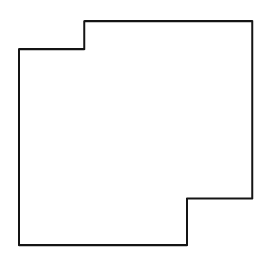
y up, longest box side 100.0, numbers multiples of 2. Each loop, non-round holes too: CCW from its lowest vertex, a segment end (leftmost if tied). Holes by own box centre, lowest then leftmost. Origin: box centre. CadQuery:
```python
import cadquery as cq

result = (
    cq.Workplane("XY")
    .moveTo(-50.0, -48.0)
    .lineTo(22.0, -48.0)
    .lineTo(22.0, -28.0)
    .lineTo(50.0, -28.0)
    .lineTo(50.0, 48.0)
    .lineTo(-22.0, 48.0)
    .lineTo(-22.0, 36.0)
    .lineTo(-50.0, 36.0)
    .close()
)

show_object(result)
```